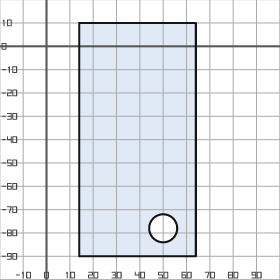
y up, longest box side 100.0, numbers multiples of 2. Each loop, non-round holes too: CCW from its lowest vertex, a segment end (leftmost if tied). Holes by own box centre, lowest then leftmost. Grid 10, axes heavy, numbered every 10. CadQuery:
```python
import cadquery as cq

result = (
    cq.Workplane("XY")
    .moveTo(14.0, -90.0)
    .lineTo(64.0, -90.0)
    .lineTo(64.0, 10.0)
    .lineTo(14.0, 10.0)
    .close()
    .moveTo(50.0, -78.0)
    .circle(6.0)
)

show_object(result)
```